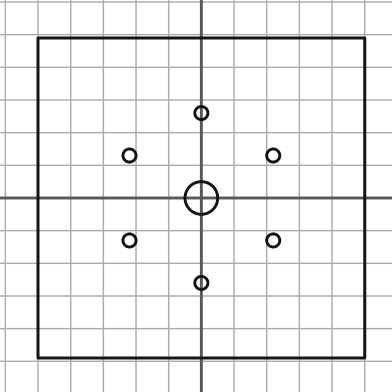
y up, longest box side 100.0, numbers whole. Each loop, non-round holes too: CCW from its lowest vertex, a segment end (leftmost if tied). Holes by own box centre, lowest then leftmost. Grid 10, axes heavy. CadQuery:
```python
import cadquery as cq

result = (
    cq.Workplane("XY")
    .moveTo(-50.0, -49.0)
    .lineTo(50.0, -49.0)
    .lineTo(50.0, 49.0)
    .lineTo(-50.0, 49.0)
    .close()
    .moveTo(0.0, -26.0)
    .circle(2.0)
    .moveTo(-22.0, -13.0)
    .circle(2.0)
    .moveTo(22.0, -13.0)
    .circle(2.0)
    .moveTo(0.0, 0.0)
    .circle(5.0)
    .moveTo(-22.0, 13.0)
    .circle(2.0)
    .moveTo(22.0, 13.0)
    .circle(2.0)
    .moveTo(0.0, 26.0)
    .circle(2.0)
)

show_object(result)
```